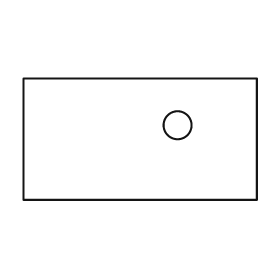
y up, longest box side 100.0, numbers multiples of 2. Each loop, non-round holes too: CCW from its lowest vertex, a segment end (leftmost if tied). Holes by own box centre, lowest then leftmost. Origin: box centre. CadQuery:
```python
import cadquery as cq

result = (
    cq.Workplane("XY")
    .moveTo(-50.0, -26.0)
    .lineTo(50.0, -26.0)
    .lineTo(50.0, 26.0)
    .lineTo(-50.0, 26.0)
    .close()
    .moveTo(16.0, 6.0)
    .circle(6.0)
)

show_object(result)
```